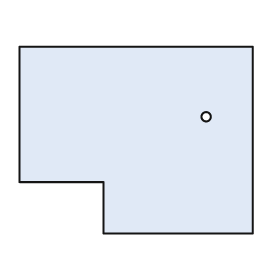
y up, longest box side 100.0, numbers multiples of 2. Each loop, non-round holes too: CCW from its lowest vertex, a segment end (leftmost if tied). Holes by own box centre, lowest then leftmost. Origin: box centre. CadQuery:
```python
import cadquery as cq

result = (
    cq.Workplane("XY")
    .moveTo(-14.0, -40.0)
    .lineTo(50.0, -40.0)
    .lineTo(50.0, 40.0)
    .lineTo(-50.0, 40.0)
    .lineTo(-50.0, -18.0)
    .lineTo(-14.0, -18.0)
    .close()
    .moveTo(30.0, 10.0)
    .circle(2.0)
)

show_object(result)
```